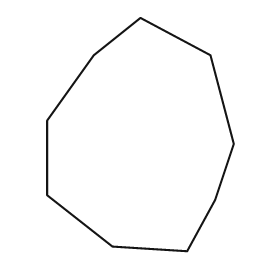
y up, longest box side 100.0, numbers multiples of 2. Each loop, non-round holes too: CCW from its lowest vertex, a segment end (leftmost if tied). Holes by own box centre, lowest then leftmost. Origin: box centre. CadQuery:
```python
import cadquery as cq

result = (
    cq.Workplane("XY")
    .moveTo(20.0, -50.0)
    .lineTo(32.0, -28.0)
    .lineTo(40.0, -4.0)
    .lineTo(30.0, 34.0)
    .lineTo(0.0, 50.0)
    .lineTo(-20.0, 34.0)
    .lineTo(-40.0, 6.0)
    .lineTo(-40.0, -26.0)
    .lineTo(-12.0, -48.0)
    .close()
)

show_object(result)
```